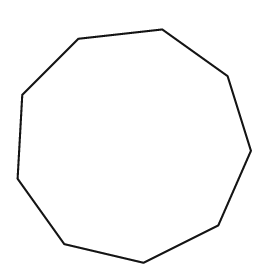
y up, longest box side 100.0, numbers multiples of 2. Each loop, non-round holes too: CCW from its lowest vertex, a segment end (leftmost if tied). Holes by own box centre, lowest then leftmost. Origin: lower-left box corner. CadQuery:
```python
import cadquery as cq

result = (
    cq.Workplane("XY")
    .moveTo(54.0, 0.0)
    .lineTo(86.0, 16.0)
    .lineTo(100.0, 48.0)
    .lineTo(90.0, 80.0)
    .lineTo(62.0, 100.0)
    .lineTo(26.0, 96.0)
    .lineTo(2.0, 72.0)
    .lineTo(0.0, 36.0)
    .lineTo(20.0, 8.0)
    .close()
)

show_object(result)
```